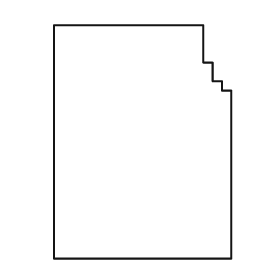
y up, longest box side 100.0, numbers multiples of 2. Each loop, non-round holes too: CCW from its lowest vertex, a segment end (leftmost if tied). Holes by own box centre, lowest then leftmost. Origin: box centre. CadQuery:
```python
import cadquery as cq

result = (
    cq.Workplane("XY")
    .moveTo(-38.0, -50.0)
    .lineTo(38.0, -50.0)
    .lineTo(38.0, 22.0)
    .lineTo(34.0, 22.0)
    .lineTo(34.0, 26.0)
    .lineTo(30.0, 26.0)
    .lineTo(30.0, 34.0)
    .lineTo(26.0, 34.0)
    .lineTo(26.0, 50.0)
    .lineTo(-38.0, 50.0)
    .close()
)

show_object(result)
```